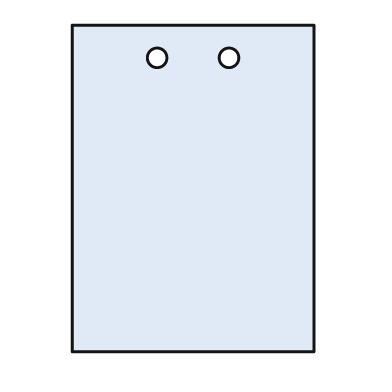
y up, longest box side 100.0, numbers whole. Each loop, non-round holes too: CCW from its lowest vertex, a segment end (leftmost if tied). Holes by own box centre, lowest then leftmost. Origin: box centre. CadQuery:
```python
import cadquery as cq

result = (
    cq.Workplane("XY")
    .moveTo(-37.0, -50.0)
    .lineTo(37.0, -50.0)
    .lineTo(37.0, 50.0)
    .lineTo(-37.0, 50.0)
    .close()
    .moveTo(-11.0, 40.0)
    .circle(3.0)
    .moveTo(11.0, 40.0)
    .circle(3.0)
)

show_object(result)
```